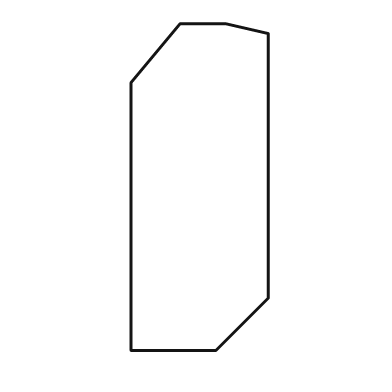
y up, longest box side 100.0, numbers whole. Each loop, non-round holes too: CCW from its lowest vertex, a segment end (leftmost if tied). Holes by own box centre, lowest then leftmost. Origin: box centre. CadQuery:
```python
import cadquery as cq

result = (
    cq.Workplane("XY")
    .moveTo(-21.0, -50.0)
    .lineTo(5.0, -50.0)
    .lineTo(21.0, -34.0)
    .lineTo(21.0, 47.0)
    .lineTo(8.0, 50.0)
    .lineTo(-6.0, 50.0)
    .lineTo(-21.0, 32.0)
    .close()
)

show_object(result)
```